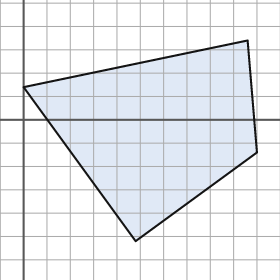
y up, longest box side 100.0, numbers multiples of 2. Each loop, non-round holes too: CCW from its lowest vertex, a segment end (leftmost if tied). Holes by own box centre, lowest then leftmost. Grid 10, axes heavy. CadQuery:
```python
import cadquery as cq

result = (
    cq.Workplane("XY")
    .moveTo(48.0, -52.0)
    .lineTo(100.0, -14.0)
    .lineTo(96.0, 34.0)
    .lineTo(0.0, 14.0)
    .close()
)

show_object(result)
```